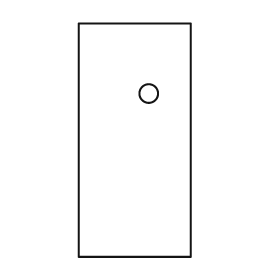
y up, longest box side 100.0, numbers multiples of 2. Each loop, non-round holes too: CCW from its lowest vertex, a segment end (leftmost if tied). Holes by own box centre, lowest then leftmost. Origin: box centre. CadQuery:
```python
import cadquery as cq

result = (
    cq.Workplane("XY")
    .moveTo(-24.0, -50.0)
    .lineTo(24.0, -50.0)
    .lineTo(24.0, 50.0)
    .lineTo(-24.0, 50.0)
    .close()
    .moveTo(6.0, 20.0)
    .circle(4.0)
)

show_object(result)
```